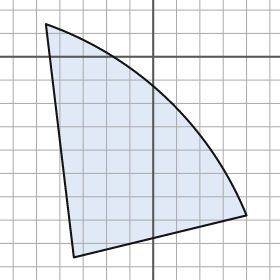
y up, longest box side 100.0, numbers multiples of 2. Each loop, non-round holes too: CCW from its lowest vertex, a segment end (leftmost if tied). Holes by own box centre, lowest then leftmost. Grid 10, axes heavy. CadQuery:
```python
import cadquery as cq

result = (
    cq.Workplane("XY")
    .moveTo(-34.0, -86.0)
    .lineTo(40.0, -68.0)
    .threePointArc((6.0, -18.0), (-46.0, 14.0))
    .close()
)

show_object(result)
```